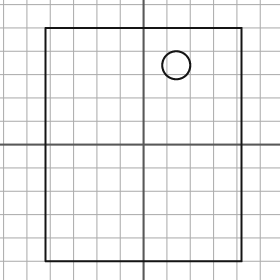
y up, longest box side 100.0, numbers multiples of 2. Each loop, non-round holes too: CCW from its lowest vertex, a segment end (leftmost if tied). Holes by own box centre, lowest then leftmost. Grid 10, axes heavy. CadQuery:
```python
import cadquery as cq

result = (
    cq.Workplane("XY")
    .moveTo(-42.0, -50.0)
    .lineTo(42.0, -50.0)
    .lineTo(42.0, 50.0)
    .lineTo(-42.0, 50.0)
    .close()
    .moveTo(14.0, 34.0)
    .circle(6.0)
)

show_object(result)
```